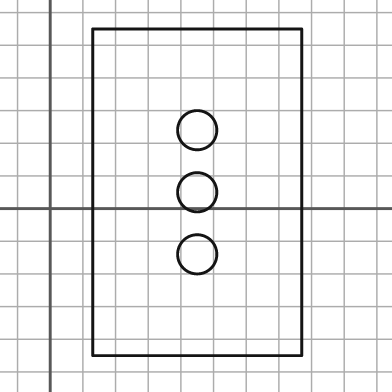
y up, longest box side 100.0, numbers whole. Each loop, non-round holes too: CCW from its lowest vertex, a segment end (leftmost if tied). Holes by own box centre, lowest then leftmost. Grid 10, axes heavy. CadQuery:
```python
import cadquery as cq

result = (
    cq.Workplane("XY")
    .moveTo(13.0, -45.0)
    .lineTo(77.0, -45.0)
    .lineTo(77.0, 55.0)
    .lineTo(13.0, 55.0)
    .close()
    .moveTo(45.0, -14.0)
    .circle(6.0)
    .moveTo(45.0, 5.0)
    .circle(6.0)
    .moveTo(45.0, 24.0)
    .circle(6.0)
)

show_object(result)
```